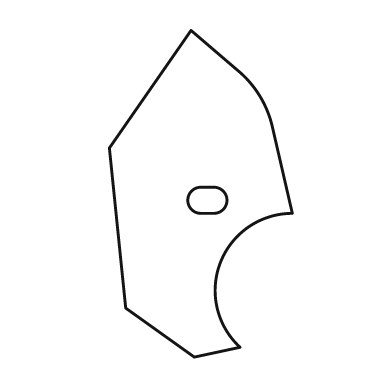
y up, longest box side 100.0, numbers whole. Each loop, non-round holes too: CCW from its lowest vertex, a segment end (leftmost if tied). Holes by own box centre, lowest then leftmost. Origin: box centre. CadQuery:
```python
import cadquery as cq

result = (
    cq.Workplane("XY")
    .moveTo(-2.0, -50.0)
    .lineTo(12.0, -47.0)
    .threePointArc((6.0, -21.0), (28.0, -6.0))
    .lineTo(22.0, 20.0)
    .threePointArc((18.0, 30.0), (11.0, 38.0))
    .lineTo(-3.0, 50.0)
    .lineTo(-28.0, 14.0)
    .lineTo(-23.0, -35.0)
    .close()
    .moveTo(0.0, -6.0)
    .lineTo(4.0, -6.0)
    .threePointArc((8.0, -2.0), (4.0, 2.0))
    .lineTo(0.0, 2.0)
    .threePointArc((-4.0, -2.0), (0.0, -6.0))
    .close()
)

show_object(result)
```